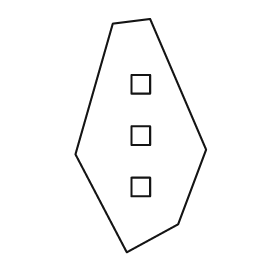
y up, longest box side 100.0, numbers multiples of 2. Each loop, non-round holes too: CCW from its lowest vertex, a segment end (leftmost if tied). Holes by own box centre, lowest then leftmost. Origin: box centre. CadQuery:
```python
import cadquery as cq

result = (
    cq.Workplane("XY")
    .moveTo(-6.0, -50.0)
    .lineTo(16.0, -38.0)
    .lineTo(28.0, -6.0)
    .lineTo(4.0, 50.0)
    .lineTo(-12.0, 48.0)
    .lineTo(-28.0, -8.0)
    .close()
    .moveTo(-4.0, -26.0)
    .lineTo(4.0, -26.0)
    .lineTo(4.0, -18.0)
    .lineTo(-4.0, -18.0)
    .close()
    .moveTo(-4.0, -4.0)
    .lineTo(4.0, -4.0)
    .lineTo(4.0, 4.0)
    .lineTo(-4.0, 4.0)
    .close()
    .moveTo(-4.0, 18.0)
    .lineTo(4.0, 18.0)
    .lineTo(4.0, 26.0)
    .lineTo(-4.0, 26.0)
    .close()
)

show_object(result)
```